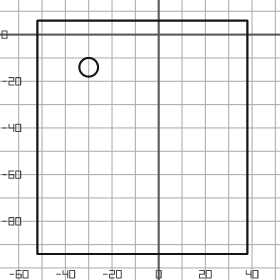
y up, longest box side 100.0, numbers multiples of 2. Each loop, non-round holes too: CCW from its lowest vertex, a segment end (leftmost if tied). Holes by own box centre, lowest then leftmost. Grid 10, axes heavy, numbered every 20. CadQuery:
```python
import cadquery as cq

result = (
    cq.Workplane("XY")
    .moveTo(-52.0, -94.0)
    .lineTo(38.0, -94.0)
    .lineTo(38.0, 6.0)
    .lineTo(-52.0, 6.0)
    .close()
    .moveTo(-30.0, -14.0)
    .circle(4.0)
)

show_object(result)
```